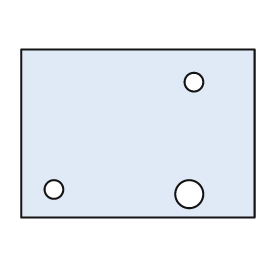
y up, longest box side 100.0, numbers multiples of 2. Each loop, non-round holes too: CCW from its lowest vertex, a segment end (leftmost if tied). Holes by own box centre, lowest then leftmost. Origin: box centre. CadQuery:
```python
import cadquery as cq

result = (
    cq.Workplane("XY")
    .moveTo(-50.0, -36.0)
    .lineTo(50.0, -36.0)
    .lineTo(50.0, 36.0)
    .lineTo(-50.0, 36.0)
    .close()
    .moveTo(22.0, -26.0)
    .circle(6.0)
    .moveTo(-36.0, -24.0)
    .circle(4.0)
    .moveTo(24.0, 22.0)
    .circle(4.0)
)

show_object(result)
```